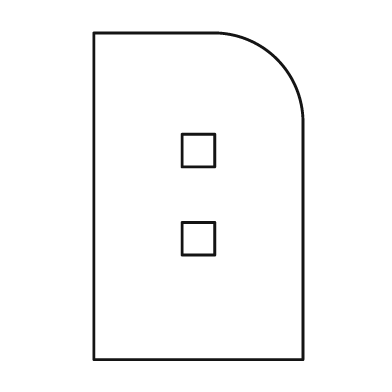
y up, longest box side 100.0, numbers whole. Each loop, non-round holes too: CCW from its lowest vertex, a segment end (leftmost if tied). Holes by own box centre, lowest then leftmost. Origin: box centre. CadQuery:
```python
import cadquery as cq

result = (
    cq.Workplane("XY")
    .moveTo(-32.0, -50.0)
    .lineTo(32.0, -50.0)
    .lineTo(32.0, 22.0)
    .threePointArc((24.0, 42.0), (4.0, 50.0))
    .lineTo(-32.0, 50.0)
    .close()
    .moveTo(-5.0, -18.0)
    .lineTo(5.0, -18.0)
    .lineTo(5.0, -8.0)
    .lineTo(-5.0, -8.0)
    .close()
    .moveTo(-5.0, 9.0)
    .lineTo(5.0, 9.0)
    .lineTo(5.0, 19.0)
    .lineTo(-5.0, 19.0)
    .close()
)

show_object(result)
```